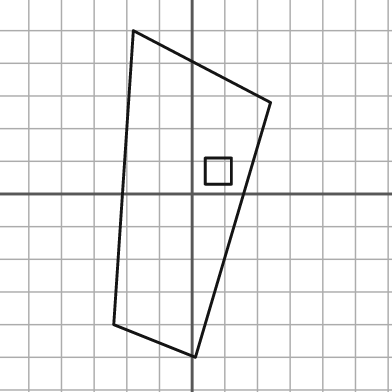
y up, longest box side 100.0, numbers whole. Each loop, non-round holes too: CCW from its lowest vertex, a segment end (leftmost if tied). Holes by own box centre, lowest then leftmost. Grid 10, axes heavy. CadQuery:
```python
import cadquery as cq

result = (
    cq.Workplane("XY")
    .moveTo(1.0, -50.0)
    .lineTo(24.0, 28.0)
    .lineTo(-18.0, 50.0)
    .lineTo(-24.0, -40.0)
    .close()
    .moveTo(4.0, 3.0)
    .lineTo(12.0, 3.0)
    .lineTo(12.0, 11.0)
    .lineTo(4.0, 11.0)
    .close()
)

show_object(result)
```